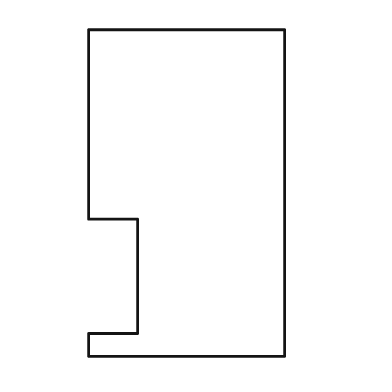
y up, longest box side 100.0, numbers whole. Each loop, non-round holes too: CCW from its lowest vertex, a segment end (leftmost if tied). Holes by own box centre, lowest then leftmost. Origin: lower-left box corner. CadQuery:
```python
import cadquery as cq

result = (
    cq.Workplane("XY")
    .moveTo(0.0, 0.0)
    .lineTo(60.0, 0.0)
    .lineTo(60.0, 100.0)
    .lineTo(0.0, 100.0)
    .lineTo(0.0, 42.0)
    .lineTo(15.0, 42.0)
    .lineTo(15.0, 7.0)
    .lineTo(0.0, 7.0)
    .close()
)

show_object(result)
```